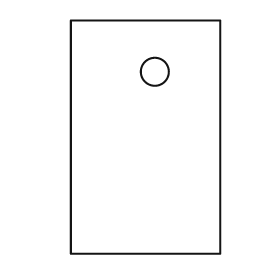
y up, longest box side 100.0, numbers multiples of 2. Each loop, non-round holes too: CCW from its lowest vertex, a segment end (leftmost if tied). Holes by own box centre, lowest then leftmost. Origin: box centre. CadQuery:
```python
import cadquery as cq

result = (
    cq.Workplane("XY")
    .moveTo(-32.0, -50.0)
    .lineTo(32.0, -50.0)
    .lineTo(32.0, 50.0)
    .lineTo(-32.0, 50.0)
    .close()
    .moveTo(4.0, 28.0)
    .circle(6.0)
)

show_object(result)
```